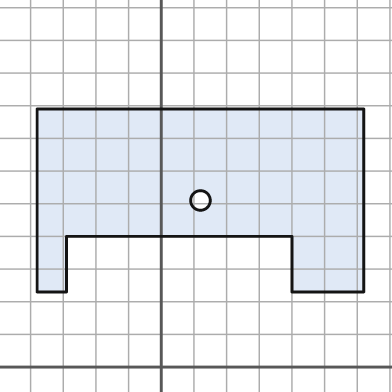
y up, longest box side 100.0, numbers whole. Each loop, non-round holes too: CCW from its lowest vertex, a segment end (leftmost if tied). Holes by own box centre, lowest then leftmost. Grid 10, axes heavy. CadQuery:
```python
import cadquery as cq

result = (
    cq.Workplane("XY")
    .moveTo(-38.0, 23.0)
    .lineTo(-29.0, 23.0)
    .lineTo(-29.0, 40.0)
    .lineTo(40.0, 40.0)
    .lineTo(40.0, 23.0)
    .lineTo(62.0, 23.0)
    .lineTo(62.0, 79.0)
    .lineTo(-38.0, 79.0)
    .close()
    .moveTo(12.0, 51.0)
    .circle(3.0)
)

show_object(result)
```